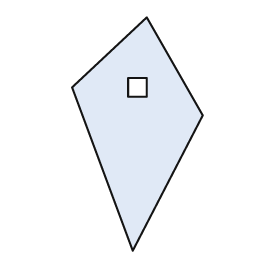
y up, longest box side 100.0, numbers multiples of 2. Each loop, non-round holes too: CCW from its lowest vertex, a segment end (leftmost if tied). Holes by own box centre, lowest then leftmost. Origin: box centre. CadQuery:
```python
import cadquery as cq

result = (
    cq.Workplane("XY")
    .moveTo(-2.0, -50.0)
    .lineTo(28.0, 8.0)
    .lineTo(4.0, 50.0)
    .lineTo(-28.0, 20.0)
    .close()
    .moveTo(-4.0, 16.0)
    .lineTo(4.0, 16.0)
    .lineTo(4.0, 24.0)
    .lineTo(-4.0, 24.0)
    .close()
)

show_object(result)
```